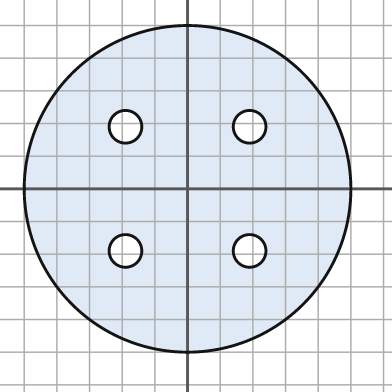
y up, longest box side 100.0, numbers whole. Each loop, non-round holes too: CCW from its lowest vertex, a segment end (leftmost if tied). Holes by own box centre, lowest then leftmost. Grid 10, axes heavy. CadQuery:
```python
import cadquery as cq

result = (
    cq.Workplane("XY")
    .moveTo(0.0, 0.0)
    .circle(50.0)
    .moveTo(-19.0, -19.0)
    .circle(5.0)
    .moveTo(19.0, -19.0)
    .circle(5.0)
    .moveTo(-19.0, 19.0)
    .circle(5.0)
    .moveTo(19.0, 19.0)
    .circle(5.0)
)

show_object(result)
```